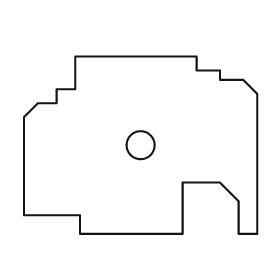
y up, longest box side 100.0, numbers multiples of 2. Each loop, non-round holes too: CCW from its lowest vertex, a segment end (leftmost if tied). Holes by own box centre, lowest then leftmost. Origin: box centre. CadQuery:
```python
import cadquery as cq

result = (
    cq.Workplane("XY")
    .moveTo(-26.0, -38.0)
    .lineTo(18.0, -38.0)
    .lineTo(18.0, -16.0)
    .lineTo(34.0, -16.0)
    .lineTo(42.0, -24.0)
    .lineTo(42.0, -38.0)
    .lineTo(50.0, -38.0)
    .lineTo(50.0, 22.0)
    .lineTo(44.0, 28.0)
    .lineTo(34.0, 28.0)
    .lineTo(34.0, 32.0)
    .lineTo(24.0, 32.0)
    .lineTo(24.0, 38.0)
    .lineTo(-28.0, 38.0)
    .lineTo(-28.0, 24.0)
    .lineTo(-36.0, 24.0)
    .lineTo(-36.0, 18.0)
    .lineTo(-44.0, 18.0)
    .lineTo(-50.0, 12.0)
    .lineTo(-50.0, -30.0)
    .lineTo(-26.0, -30.0)
    .close()
    .moveTo(0.0, 0.0)
    .circle(6.0)
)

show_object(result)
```